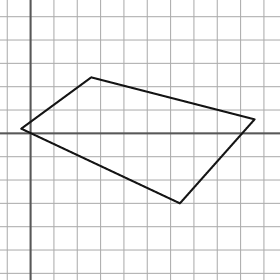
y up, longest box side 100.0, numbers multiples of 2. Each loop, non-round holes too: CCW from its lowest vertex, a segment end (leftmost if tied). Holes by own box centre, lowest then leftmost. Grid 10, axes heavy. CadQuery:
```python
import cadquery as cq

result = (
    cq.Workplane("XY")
    .moveTo(64.0, -30.0)
    .lineTo(96.0, 6.0)
    .lineTo(26.0, 24.0)
    .lineTo(-4.0, 2.0)
    .close()
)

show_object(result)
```